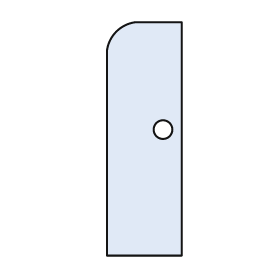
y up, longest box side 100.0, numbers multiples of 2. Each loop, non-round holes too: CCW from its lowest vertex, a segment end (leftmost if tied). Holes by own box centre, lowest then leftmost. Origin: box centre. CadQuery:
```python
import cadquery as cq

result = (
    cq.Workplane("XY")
    .moveTo(-16.0, -50.0)
    .lineTo(16.0, -50.0)
    .lineTo(16.0, 50.0)
    .lineTo(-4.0, 50.0)
    .threePointArc((-12.0, 46.0), (-16.0, 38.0))
    .close()
    .moveTo(8.0, 4.0)
    .circle(4.0)
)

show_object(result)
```